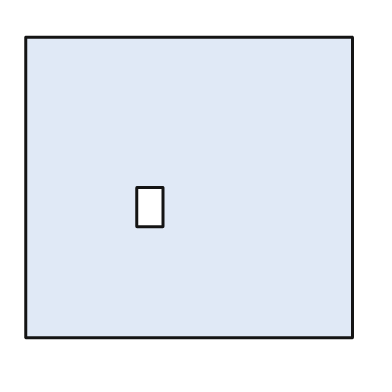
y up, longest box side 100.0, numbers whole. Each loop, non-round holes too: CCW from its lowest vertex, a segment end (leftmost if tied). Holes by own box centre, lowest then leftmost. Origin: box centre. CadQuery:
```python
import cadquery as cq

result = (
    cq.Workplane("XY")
    .moveTo(-50.0, -46.0)
    .lineTo(50.0, -46.0)
    .lineTo(50.0, 46.0)
    .lineTo(-50.0, 46.0)
    .close()
    .moveTo(-16.0, -12.0)
    .lineTo(-8.0, -12.0)
    .lineTo(-8.0, 0.0)
    .lineTo(-16.0, 0.0)
    .close()
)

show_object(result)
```